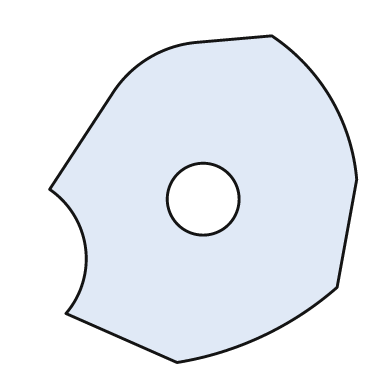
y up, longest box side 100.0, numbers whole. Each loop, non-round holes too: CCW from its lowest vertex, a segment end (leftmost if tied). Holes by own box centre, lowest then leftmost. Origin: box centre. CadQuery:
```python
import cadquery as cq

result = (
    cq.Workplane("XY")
    .moveTo(-8.0, -50.0)
    .threePointArc((18.0, -42.0), (41.0, -27.0))
    .lineTo(47.0, 6.0)
    .threePointArc((39.0, 31.0), (21.0, 50.0))
    .lineTo(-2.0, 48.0)
    .threePointArc((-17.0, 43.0), (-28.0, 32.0))
    .lineTo(-47.0, 3.0)
    .threePointArc((-36.0, -15.0), (-42.0, -35.0))
    .close()
    .moveTo(0.0, 0.0)
    .circle(11.0)
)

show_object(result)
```